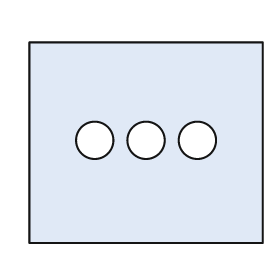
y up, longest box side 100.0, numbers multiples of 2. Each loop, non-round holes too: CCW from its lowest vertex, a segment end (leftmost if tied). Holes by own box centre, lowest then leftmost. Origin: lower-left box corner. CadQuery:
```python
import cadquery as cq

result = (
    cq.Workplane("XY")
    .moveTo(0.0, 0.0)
    .lineTo(100.0, 0.0)
    .lineTo(100.0, 86.0)
    .lineTo(0.0, 86.0)
    .close()
    .moveTo(28.0, 44.0)
    .circle(8.0)
    .moveTo(50.0, 44.0)
    .circle(8.0)
    .moveTo(72.0, 44.0)
    .circle(8.0)
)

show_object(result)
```